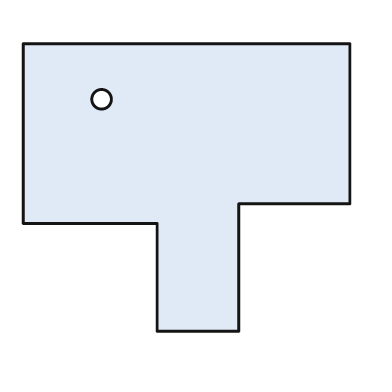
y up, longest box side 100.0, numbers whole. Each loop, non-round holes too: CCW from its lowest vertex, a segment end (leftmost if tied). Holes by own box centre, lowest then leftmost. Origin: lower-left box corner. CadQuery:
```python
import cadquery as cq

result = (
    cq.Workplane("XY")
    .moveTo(41.0, 0.0)
    .lineTo(66.0, 0.0)
    .lineTo(66.0, 39.0)
    .lineTo(100.0, 39.0)
    .lineTo(100.0, 88.0)
    .lineTo(0.0, 88.0)
    .lineTo(0.0, 33.0)
    .lineTo(41.0, 33.0)
    .close()
    .moveTo(24.0, 71.0)
    .circle(3.0)
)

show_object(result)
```